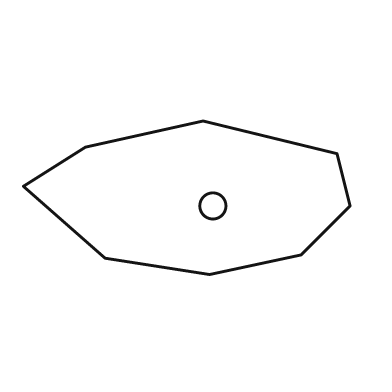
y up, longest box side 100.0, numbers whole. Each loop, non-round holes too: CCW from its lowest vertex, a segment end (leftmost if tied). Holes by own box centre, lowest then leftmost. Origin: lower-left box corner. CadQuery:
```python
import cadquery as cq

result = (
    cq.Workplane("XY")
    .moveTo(57.0, 0.0)
    .lineTo(85.0, 6.0)
    .lineTo(100.0, 21.0)
    .lineTo(96.0, 37.0)
    .lineTo(55.0, 47.0)
    .lineTo(19.0, 39.0)
    .lineTo(0.0, 27.0)
    .lineTo(25.0, 5.0)
    .close()
    .moveTo(58.0, 21.0)
    .circle(4.0)
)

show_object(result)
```